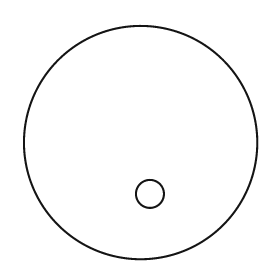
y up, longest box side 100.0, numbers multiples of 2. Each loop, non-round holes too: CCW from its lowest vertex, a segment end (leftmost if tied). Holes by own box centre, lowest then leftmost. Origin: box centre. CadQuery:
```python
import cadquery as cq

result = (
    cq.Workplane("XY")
    .moveTo(0.0, 0.0)
    .circle(50.0)
    .moveTo(4.0, -22.0)
    .circle(6.0)
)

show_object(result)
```